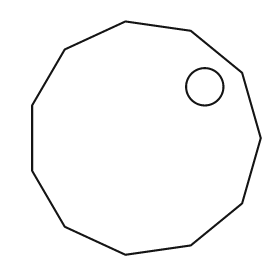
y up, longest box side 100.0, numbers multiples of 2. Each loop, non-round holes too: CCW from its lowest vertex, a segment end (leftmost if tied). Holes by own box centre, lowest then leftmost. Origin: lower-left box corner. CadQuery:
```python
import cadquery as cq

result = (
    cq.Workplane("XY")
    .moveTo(40.0, 0.0)
    .lineTo(68.0, 4.0)
    .lineTo(90.0, 22.0)
    .lineTo(98.0, 50.0)
    .lineTo(90.0, 78.0)
    .lineTo(68.0, 96.0)
    .lineTo(40.0, 100.0)
    .lineTo(14.0, 88.0)
    .lineTo(0.0, 64.0)
    .lineTo(0.0, 36.0)
    .lineTo(14.0, 12.0)
    .close()
    .moveTo(74.0, 72.0)
    .circle(8.0)
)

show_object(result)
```